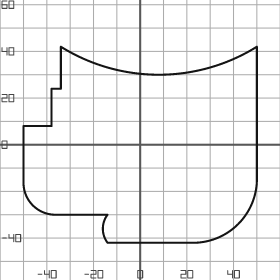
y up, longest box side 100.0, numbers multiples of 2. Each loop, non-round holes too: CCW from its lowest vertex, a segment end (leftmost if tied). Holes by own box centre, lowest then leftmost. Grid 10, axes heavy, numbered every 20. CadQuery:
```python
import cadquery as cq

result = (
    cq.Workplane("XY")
    .moveTo(-14.0, -42.0)
    .lineTo(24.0, -42.0)
    .threePointArc((42.0, -34.0), (50.0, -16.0))
    .lineTo(50.0, 42.0)
    .threePointArc((8.0, 30.0), (-34.0, 42.0))
    .lineTo(-34.0, 24.0)
    .lineTo(-38.0, 24.0)
    .lineTo(-38.0, 8.0)
    .lineTo(-50.0, 8.0)
    .lineTo(-50.0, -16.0)
    .threePointArc((-46.0, -26.0), (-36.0, -30.0))
    .lineTo(-14.0, -30.0)
    .threePointArc((-16.0, -36.0), (-14.0, -42.0))
    .close()
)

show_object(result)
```